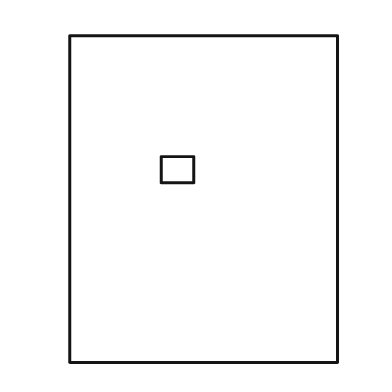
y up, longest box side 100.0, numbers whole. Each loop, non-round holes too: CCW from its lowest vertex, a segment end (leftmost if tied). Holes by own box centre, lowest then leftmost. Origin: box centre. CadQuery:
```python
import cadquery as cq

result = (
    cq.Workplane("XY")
    .moveTo(-41.0, -50.0)
    .lineTo(41.0, -50.0)
    .lineTo(41.0, 50.0)
    .lineTo(-41.0, 50.0)
    .close()
    .moveTo(-13.0, 5.0)
    .lineTo(-3.0, 5.0)
    .lineTo(-3.0, 13.0)
    .lineTo(-13.0, 13.0)
    .close()
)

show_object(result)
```